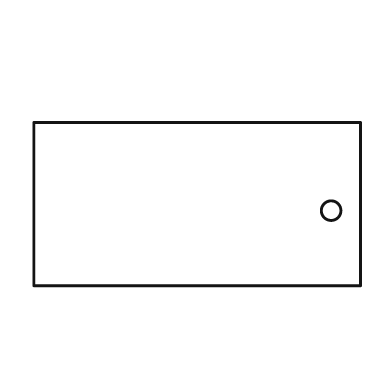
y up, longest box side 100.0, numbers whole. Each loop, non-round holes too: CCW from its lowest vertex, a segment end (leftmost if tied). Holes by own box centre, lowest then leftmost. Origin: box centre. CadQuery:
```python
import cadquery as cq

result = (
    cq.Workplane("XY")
    .moveTo(-50.0, -25.0)
    .lineTo(50.0, -25.0)
    .lineTo(50.0, 25.0)
    .lineTo(-50.0, 25.0)
    .close()
    .moveTo(41.0, -2.0)
    .circle(3.0)
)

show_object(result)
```